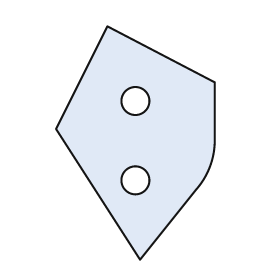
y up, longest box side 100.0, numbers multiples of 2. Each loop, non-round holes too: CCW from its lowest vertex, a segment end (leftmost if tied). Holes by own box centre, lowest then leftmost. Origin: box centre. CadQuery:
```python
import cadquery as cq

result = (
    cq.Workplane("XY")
    .moveTo(2.0, -50.0)
    .lineTo(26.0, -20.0)
    .threePointArc((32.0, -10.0), (34.0, 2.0))
    .lineTo(34.0, 26.0)
    .lineTo(-12.0, 50.0)
    .lineTo(-34.0, 6.0)
    .close()
    .moveTo(0.0, -16.0)
    .circle(6.0)
    .moveTo(0.0, 18.0)
    .circle(6.0)
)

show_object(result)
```